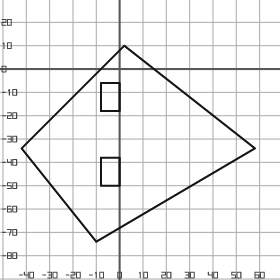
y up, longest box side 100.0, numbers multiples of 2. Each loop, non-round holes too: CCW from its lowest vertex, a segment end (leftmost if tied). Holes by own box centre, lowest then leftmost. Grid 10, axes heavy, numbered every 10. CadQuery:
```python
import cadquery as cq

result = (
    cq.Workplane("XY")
    .moveTo(-10.0, -74.0)
    .lineTo(58.0, -34.0)
    .lineTo(2.0, 10.0)
    .lineTo(-42.0, -34.0)
    .close()
    .moveTo(-8.0, -50.0)
    .lineTo(0.0, -50.0)
    .lineTo(0.0, -38.0)
    .lineTo(-8.0, -38.0)
    .close()
    .moveTo(-8.0, -18.0)
    .lineTo(0.0, -18.0)
    .lineTo(0.0, -6.0)
    .lineTo(-8.0, -6.0)
    .close()
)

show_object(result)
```